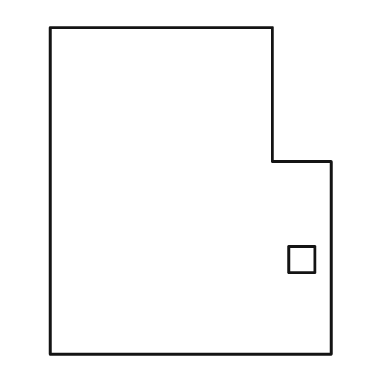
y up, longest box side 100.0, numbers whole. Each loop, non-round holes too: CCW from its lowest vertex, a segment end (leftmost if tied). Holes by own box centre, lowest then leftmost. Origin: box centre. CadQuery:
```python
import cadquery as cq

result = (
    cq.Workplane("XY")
    .moveTo(-43.0, -50.0)
    .lineTo(43.0, -50.0)
    .lineTo(43.0, 9.0)
    .lineTo(25.0, 9.0)
    .lineTo(25.0, 50.0)
    .lineTo(-43.0, 50.0)
    .close()
    .moveTo(30.0, -25.0)
    .lineTo(38.0, -25.0)
    .lineTo(38.0, -17.0)
    .lineTo(30.0, -17.0)
    .close()
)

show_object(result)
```